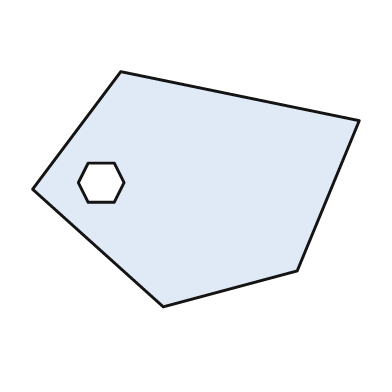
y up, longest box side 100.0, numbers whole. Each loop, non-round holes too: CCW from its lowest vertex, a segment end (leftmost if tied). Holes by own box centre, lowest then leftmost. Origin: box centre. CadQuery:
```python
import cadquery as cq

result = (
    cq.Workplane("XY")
    .moveTo(-10.0, -36.0)
    .lineTo(31.0, -25.0)
    .lineTo(50.0, 21.0)
    .lineTo(-23.0, 36.0)
    .lineTo(-50.0, 0.0)
    .close()
    .moveTo(-33.0, -4.0)
    .lineTo(-25.0, -4.0)
    .lineTo(-22.0, 2.0)
    .lineTo(-25.0, 8.0)
    .lineTo(-33.0, 8.0)
    .lineTo(-36.0, 2.0)
    .close()
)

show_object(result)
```